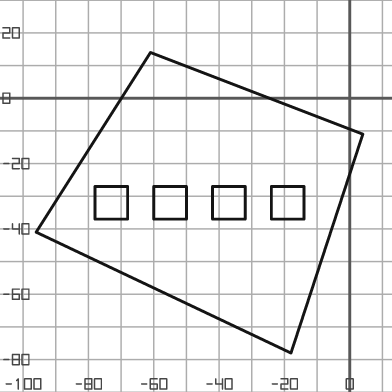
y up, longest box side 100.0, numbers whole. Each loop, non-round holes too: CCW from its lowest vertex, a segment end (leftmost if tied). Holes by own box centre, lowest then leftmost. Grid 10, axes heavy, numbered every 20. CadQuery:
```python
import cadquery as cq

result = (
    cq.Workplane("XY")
    .moveTo(-18.0, -78.0)
    .lineTo(4.0, -11.0)
    .lineTo(-61.0, 14.0)
    .lineTo(-96.0, -41.0)
    .close()
    .moveTo(-78.0, -37.0)
    .lineTo(-68.0, -37.0)
    .lineTo(-68.0, -27.0)
    .lineTo(-78.0, -27.0)
    .close()
    .moveTo(-60.0, -37.0)
    .lineTo(-50.0, -37.0)
    .lineTo(-50.0, -27.0)
    .lineTo(-60.0, -27.0)
    .close()
    .moveTo(-42.0, -37.0)
    .lineTo(-32.0, -37.0)
    .lineTo(-32.0, -27.0)
    .lineTo(-42.0, -27.0)
    .close()
    .moveTo(-24.0, -37.0)
    .lineTo(-14.0, -37.0)
    .lineTo(-14.0, -27.0)
    .lineTo(-24.0, -27.0)
    .close()
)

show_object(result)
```